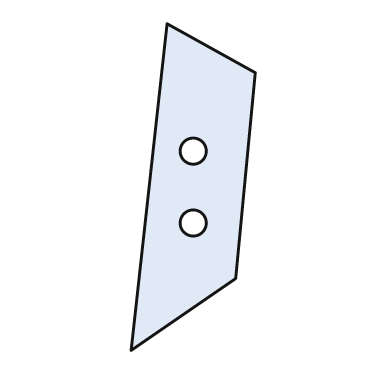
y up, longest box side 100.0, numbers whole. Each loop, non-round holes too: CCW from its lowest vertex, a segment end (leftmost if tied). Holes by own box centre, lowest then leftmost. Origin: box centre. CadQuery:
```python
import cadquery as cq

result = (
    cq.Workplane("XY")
    .moveTo(-19.0, -50.0)
    .lineTo(13.0, -28.0)
    .lineTo(19.0, 35.0)
    .lineTo(-8.0, 50.0)
    .close()
    .moveTo(0.0, -11.0)
    .circle(4.0)
    .moveTo(0.0, 11.0)
    .circle(4.0)
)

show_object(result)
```